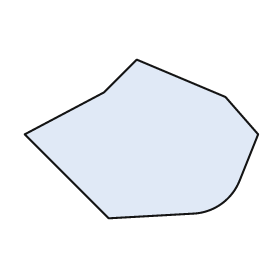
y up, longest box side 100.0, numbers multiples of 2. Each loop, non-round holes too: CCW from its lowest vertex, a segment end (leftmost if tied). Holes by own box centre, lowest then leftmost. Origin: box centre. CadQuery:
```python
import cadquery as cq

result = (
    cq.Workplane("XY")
    .moveTo(-14.0, -34.0)
    .lineTo(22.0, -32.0)
    .threePointArc((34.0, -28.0), (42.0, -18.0))
    .lineTo(50.0, 2.0)
    .lineTo(36.0, 18.0)
    .lineTo(-2.0, 34.0)
    .lineTo(-16.0, 20.0)
    .lineTo(-50.0, 2.0)
    .close()
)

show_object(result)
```